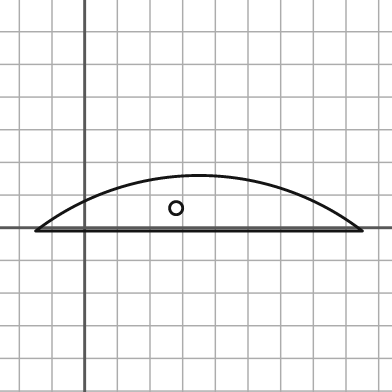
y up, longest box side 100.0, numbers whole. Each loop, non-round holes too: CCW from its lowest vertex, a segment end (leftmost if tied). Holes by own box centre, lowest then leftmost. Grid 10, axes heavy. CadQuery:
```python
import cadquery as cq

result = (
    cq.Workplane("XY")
    .moveTo(-15.0, -1.0)
    .lineTo(85.0, -1.0)
    .threePointArc((35.0, 16.0), (-15.0, -1.0))
    .close()
    .moveTo(28.0, 6.0)
    .circle(2.0)
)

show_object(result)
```